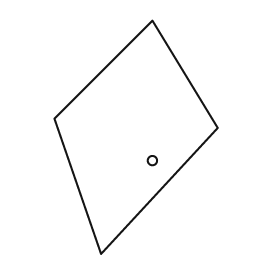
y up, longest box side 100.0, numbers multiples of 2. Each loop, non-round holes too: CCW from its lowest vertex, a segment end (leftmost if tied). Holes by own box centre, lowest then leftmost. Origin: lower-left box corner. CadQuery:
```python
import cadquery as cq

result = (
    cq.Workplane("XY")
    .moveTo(20.0, 0.0)
    .lineTo(70.0, 54.0)
    .lineTo(42.0, 100.0)
    .lineTo(0.0, 58.0)
    .close()
    .moveTo(42.0, 40.0)
    .circle(2.0)
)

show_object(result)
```